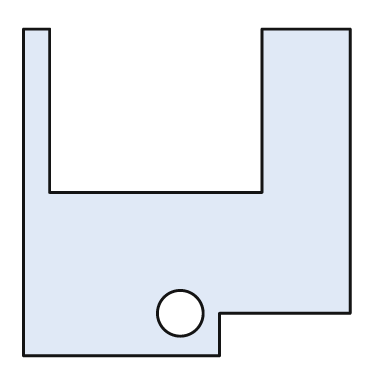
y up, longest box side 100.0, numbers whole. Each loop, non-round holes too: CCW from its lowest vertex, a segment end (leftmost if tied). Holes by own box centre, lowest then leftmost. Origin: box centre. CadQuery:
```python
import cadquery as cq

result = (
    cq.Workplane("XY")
    .moveTo(-50.0, -50.0)
    .lineTo(10.0, -50.0)
    .lineTo(10.0, -37.0)
    .lineTo(50.0, -37.0)
    .lineTo(50.0, 50.0)
    .lineTo(23.0, 50.0)
    .lineTo(23.0, 0.0)
    .lineTo(-42.0, 0.0)
    .lineTo(-42.0, 50.0)
    .lineTo(-50.0, 50.0)
    .close()
    .moveTo(-2.0, -37.0)
    .circle(7.0)
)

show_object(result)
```